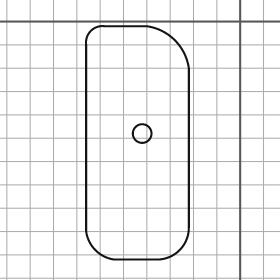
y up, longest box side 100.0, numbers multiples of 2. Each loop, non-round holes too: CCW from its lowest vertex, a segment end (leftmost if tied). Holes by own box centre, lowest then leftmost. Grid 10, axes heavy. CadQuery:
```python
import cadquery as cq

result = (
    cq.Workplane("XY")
    .moveTo(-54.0, -102.0)
    .lineTo(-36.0, -102.0)
    .threePointArc((-26.0, -98.0), (-22.0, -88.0))
    .lineTo(-22.0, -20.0)
    .threePointArc((-28.0, -8.0), (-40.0, -2.0))
    .lineTo(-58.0, -2.0)
    .threePointArc((-64.0, -4.0), (-66.0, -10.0))
    .lineTo(-66.0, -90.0)
    .threePointArc((-62.0, -98.0), (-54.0, -102.0))
    .close()
    .moveTo(-42.0, -48.0)
    .circle(4.0)
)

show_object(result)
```